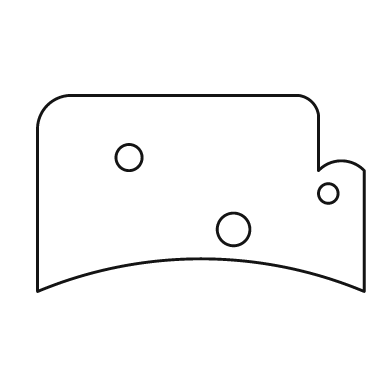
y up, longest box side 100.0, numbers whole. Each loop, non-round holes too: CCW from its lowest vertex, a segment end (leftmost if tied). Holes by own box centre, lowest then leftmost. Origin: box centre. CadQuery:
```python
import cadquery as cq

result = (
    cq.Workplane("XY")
    .moveTo(-50.0, -30.0)
    .threePointArc((0.0, -20.0), (50.0, -30.0))
    .lineTo(50.0, 7.0)
    .threePointArc((43.0, 10.0), (36.0, 7.0))
    .lineTo(36.0, 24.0)
    .threePointArc((34.0, 28.0), (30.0, 30.0))
    .lineTo(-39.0, 30.0)
    .threePointArc((-47.0, 27.0), (-50.0, 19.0))
    .close()
    .moveTo(10.0, -11.0)
    .circle(5.0)
    .moveTo(39.0, 0.0)
    .circle(3.0)
    .moveTo(-22.0, 11.0)
    .circle(4.0)
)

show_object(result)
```